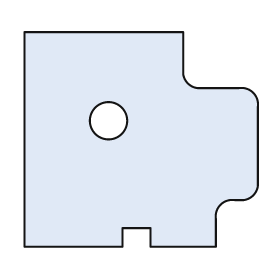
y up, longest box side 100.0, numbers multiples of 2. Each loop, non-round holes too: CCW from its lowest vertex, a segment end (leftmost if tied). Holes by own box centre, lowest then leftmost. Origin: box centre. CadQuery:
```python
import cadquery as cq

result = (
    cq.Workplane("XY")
    .moveTo(-50.0, -46.0)
    .lineTo(-8.0, -46.0)
    .lineTo(-8.0, -38.0)
    .lineTo(4.0, -38.0)
    .lineTo(4.0, -46.0)
    .lineTo(32.0, -46.0)
    .lineTo(32.0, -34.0)
    .threePointArc((34.0, -28.0), (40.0, -26.0))
    .lineTo(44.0, -26.0)
    .threePointArc((48.0, -24.0), (50.0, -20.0))
    .lineTo(50.0, 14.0)
    .threePointArc((48.0, 20.0), (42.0, 22.0))
    .lineTo(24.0, 22.0)
    .threePointArc((20.0, 24.0), (18.0, 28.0))
    .lineTo(18.0, 46.0)
    .lineTo(-50.0, 46.0)
    .close()
    .moveTo(-14.0, 8.0)
    .circle(8.0)
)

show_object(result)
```